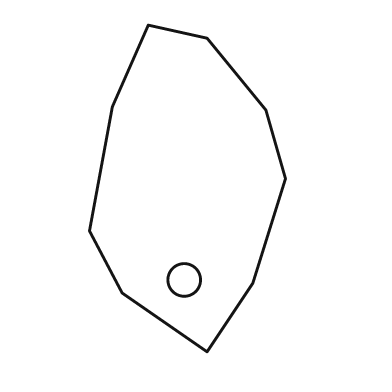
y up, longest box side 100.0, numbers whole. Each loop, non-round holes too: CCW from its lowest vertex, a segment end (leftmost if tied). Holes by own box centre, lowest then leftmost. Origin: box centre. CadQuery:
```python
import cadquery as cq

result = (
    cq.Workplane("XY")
    .moveTo(6.0, -50.0)
    .lineTo(20.0, -29.0)
    .lineTo(30.0, 3.0)
    .lineTo(24.0, 24.0)
    .lineTo(6.0, 46.0)
    .lineTo(-12.0, 50.0)
    .lineTo(-23.0, 25.0)
    .lineTo(-30.0, -13.0)
    .lineTo(-20.0, -32.0)
    .close()
    .moveTo(-1.0, -28.0)
    .circle(5.0)
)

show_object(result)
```